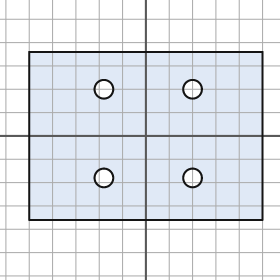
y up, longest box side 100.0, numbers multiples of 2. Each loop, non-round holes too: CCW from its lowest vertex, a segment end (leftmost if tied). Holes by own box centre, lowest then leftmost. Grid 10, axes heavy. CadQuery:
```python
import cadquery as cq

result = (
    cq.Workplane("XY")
    .moveTo(-50.0, -36.0)
    .lineTo(50.0, -36.0)
    .lineTo(50.0, 36.0)
    .lineTo(-50.0, 36.0)
    .close()
    .moveTo(-18.0, -18.0)
    .circle(4.0)
    .moveTo(20.0, -18.0)
    .circle(4.0)
    .moveTo(-18.0, 20.0)
    .circle(4.0)
    .moveTo(20.0, 20.0)
    .circle(4.0)
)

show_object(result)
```